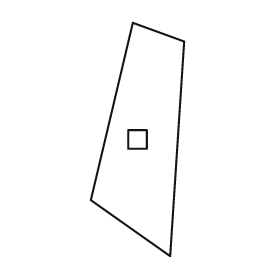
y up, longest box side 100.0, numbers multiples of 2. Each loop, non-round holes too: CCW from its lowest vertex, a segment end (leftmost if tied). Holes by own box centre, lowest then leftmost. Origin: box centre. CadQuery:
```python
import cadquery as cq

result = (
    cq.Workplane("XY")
    .moveTo(14.0, -50.0)
    .lineTo(20.0, 42.0)
    .lineTo(-2.0, 50.0)
    .lineTo(-20.0, -26.0)
    .close()
    .moveTo(-4.0, -4.0)
    .lineTo(4.0, -4.0)
    .lineTo(4.0, 4.0)
    .lineTo(-4.0, 4.0)
    .close()
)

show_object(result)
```